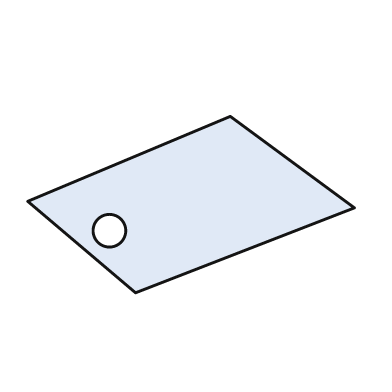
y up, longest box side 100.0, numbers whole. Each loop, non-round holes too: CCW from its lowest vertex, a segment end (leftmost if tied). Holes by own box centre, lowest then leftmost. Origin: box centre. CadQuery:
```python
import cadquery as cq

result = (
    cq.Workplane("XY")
    .moveTo(-17.0, -27.0)
    .lineTo(50.0, -1.0)
    .lineTo(12.0, 27.0)
    .lineTo(-50.0, 1.0)
    .close()
    .moveTo(-25.0, -8.0)
    .circle(5.0)
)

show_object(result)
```